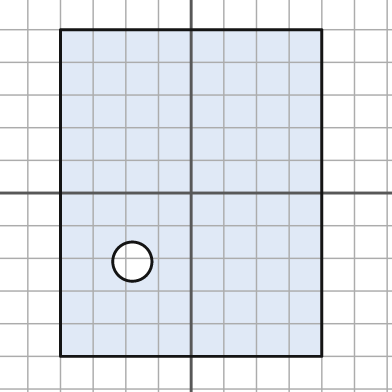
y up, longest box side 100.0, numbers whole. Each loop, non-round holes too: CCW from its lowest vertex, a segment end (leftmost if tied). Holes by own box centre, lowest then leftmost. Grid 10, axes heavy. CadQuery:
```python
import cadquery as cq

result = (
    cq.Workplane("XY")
    .moveTo(-40.0, -50.0)
    .lineTo(40.0, -50.0)
    .lineTo(40.0, 50.0)
    .lineTo(-40.0, 50.0)
    .close()
    .moveTo(-18.0, -21.0)
    .circle(6.0)
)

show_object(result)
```